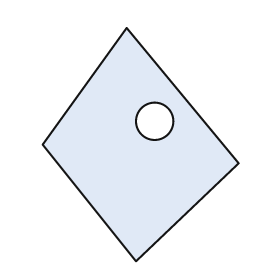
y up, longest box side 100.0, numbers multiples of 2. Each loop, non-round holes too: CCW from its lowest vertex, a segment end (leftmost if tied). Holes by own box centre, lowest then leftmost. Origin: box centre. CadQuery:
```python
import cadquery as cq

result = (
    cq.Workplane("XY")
    .moveTo(-2.0, -50.0)
    .lineTo(42.0, -8.0)
    .lineTo(-6.0, 50.0)
    .lineTo(-42.0, 0.0)
    .close()
    .moveTo(6.0, 10.0)
    .circle(8.0)
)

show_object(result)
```